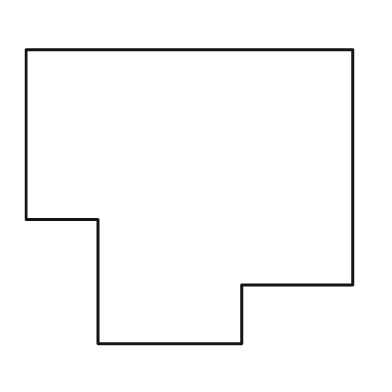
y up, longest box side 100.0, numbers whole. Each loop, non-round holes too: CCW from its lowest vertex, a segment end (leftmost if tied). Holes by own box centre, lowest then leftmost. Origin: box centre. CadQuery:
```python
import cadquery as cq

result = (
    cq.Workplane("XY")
    .moveTo(-28.0, -45.0)
    .lineTo(16.0, -45.0)
    .lineTo(16.0, -27.0)
    .lineTo(50.0, -27.0)
    .lineTo(50.0, 45.0)
    .lineTo(-50.0, 45.0)
    .lineTo(-50.0, -7.0)
    .lineTo(-28.0, -7.0)
    .close()
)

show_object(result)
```